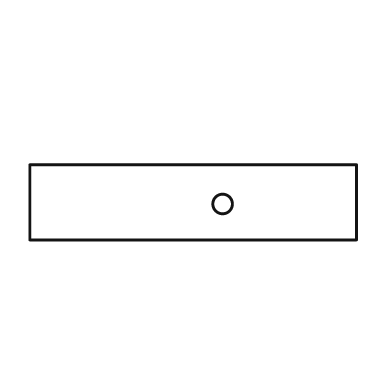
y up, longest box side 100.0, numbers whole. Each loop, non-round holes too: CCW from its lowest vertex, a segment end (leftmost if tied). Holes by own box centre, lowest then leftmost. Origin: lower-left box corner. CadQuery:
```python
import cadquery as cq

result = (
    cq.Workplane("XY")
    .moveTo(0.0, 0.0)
    .lineTo(100.0, 0.0)
    .lineTo(100.0, 23.0)
    .lineTo(0.0, 23.0)
    .close()
    .moveTo(59.0, 11.0)
    .circle(3.0)
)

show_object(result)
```